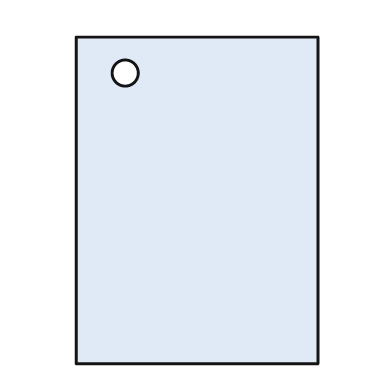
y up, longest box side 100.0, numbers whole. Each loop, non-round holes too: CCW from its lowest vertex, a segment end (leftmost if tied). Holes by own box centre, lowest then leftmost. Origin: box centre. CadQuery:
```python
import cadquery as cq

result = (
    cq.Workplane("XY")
    .moveTo(-37.0, -50.0)
    .lineTo(37.0, -50.0)
    .lineTo(37.0, 50.0)
    .lineTo(-37.0, 50.0)
    .close()
    .moveTo(-22.0, 39.0)
    .circle(4.0)
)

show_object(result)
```